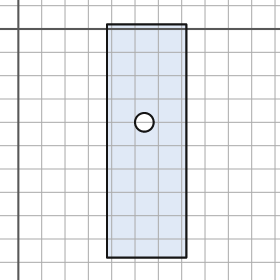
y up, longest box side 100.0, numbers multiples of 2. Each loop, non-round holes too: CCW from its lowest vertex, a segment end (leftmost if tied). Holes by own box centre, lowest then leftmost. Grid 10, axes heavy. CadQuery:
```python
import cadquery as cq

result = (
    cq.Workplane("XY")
    .moveTo(38.0, -98.0)
    .lineTo(72.0, -98.0)
    .lineTo(72.0, 2.0)
    .lineTo(38.0, 2.0)
    .close()
    .moveTo(54.0, -40.0)
    .circle(4.0)
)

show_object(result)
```